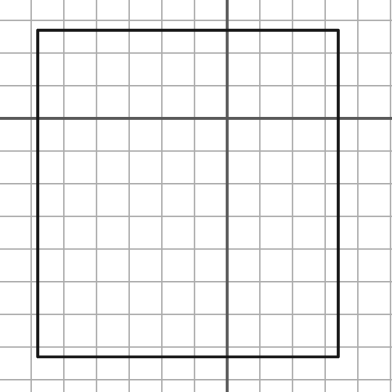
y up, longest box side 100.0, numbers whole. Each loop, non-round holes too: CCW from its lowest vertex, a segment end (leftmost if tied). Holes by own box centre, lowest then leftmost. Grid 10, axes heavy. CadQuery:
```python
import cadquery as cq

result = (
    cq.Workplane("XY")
    .moveTo(-58.0, -73.0)
    .lineTo(34.0, -73.0)
    .lineTo(34.0, 27.0)
    .lineTo(-58.0, 27.0)
    .close()
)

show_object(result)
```